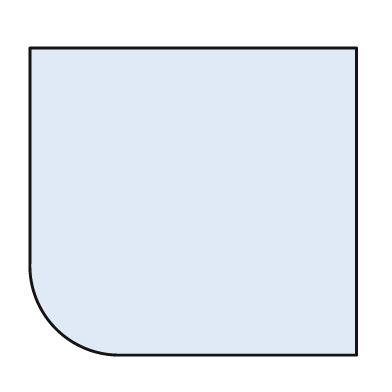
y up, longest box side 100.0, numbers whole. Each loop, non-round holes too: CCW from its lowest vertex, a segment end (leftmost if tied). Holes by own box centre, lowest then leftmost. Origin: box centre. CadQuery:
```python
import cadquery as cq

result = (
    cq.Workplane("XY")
    .moveTo(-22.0, -47.0)
    .lineTo(50.0, -47.0)
    .lineTo(50.0, 47.0)
    .lineTo(-50.0, 47.0)
    .lineTo(-50.0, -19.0)
    .threePointArc((-42.0, -39.0), (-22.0, -47.0))
    .close()
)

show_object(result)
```